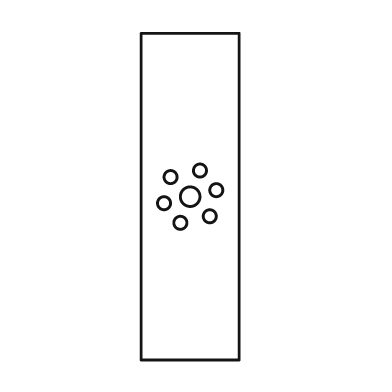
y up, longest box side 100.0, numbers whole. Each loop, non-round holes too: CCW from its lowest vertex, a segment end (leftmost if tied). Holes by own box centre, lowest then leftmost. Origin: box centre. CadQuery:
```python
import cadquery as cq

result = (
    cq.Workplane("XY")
    .moveTo(-15.0, -50.0)
    .lineTo(15.0, -50.0)
    .lineTo(15.0, 50.0)
    .lineTo(-15.0, 50.0)
    .close()
    .moveTo(-3.0, -8.0)
    .circle(2.0)
    .moveTo(6.0, -6.0)
    .circle(2.0)
    .moveTo(-8.0, -2.0)
    .circle(2.0)
    .moveTo(0.0, 0.0)
    .circle(3.0)
    .moveTo(8.0, 2.0)
    .circle(2.0)
    .moveTo(-6.0, 6.0)
    .circle(2.0)
    .moveTo(3.0, 8.0)
    .circle(2.0)
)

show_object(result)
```